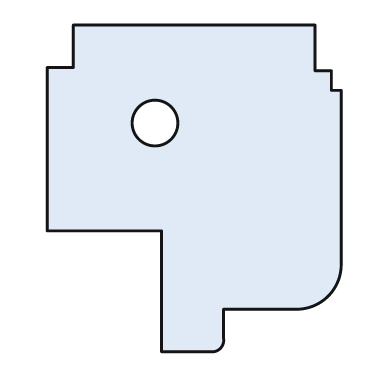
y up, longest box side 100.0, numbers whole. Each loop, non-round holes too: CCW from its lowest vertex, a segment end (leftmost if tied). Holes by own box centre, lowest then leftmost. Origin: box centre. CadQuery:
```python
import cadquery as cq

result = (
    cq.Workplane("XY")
    .moveTo(-10.0, -50.0)
    .lineTo(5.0, -50.0)
    .threePointArc((8.0, -49.0), (9.0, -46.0))
    .lineTo(9.0, -37.0)
    .lineTo(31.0, -37.0)
    .threePointArc((41.0, -33.0), (45.0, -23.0))
    .lineTo(45.0, 30.0)
    .lineTo(42.0, 30.0)
    .lineTo(42.0, 36.0)
    .lineTo(37.0, 36.0)
    .lineTo(37.0, 50.0)
    .lineTo(-37.0, 50.0)
    .lineTo(-37.0, 37.0)
    .lineTo(-45.0, 37.0)
    .lineTo(-45.0, -13.0)
    .lineTo(-10.0, -13.0)
    .close()
    .moveTo(-12.0, 20.0)
    .circle(7.0)
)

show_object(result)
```